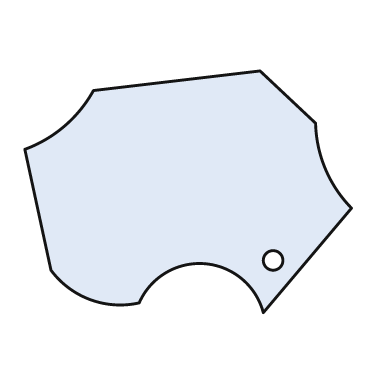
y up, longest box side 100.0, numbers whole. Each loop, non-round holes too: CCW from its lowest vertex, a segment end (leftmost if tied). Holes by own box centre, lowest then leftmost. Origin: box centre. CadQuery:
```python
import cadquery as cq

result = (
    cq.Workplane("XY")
    .moveTo(23.0, -37.0)
    .lineTo(50.0, -5.0)
    .threePointArc((42.0, 7.0), (39.0, 21.0))
    .lineTo(22.0, 37.0)
    .lineTo(-29.0, 31.0)
    .threePointArc((-38.0, 20.0), (-50.0, 13.0))
    .lineTo(-42.0, -24.0)
    .threePointArc((-30.0, -33.0), (-15.0, -34.0))
    .threePointArc((5.0, -22.0), (23.0, -37.0))
    .close()
    .moveTo(26.0, -21.0)
    .circle(3.0)
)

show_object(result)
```